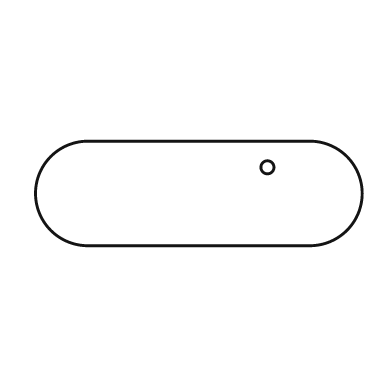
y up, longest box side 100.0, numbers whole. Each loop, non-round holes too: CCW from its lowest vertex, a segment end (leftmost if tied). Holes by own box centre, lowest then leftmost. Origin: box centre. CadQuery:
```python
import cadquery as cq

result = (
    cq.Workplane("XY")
    .moveTo(-34.0, -16.0)
    .lineTo(34.0, -16.0)
    .threePointArc((50.0, 0.0), (34.0, 16.0))
    .lineTo(-34.0, 16.0)
    .threePointArc((-50.0, 0.0), (-34.0, -16.0))
    .close()
    .moveTo(21.0, 8.0)
    .circle(2.0)
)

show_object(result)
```